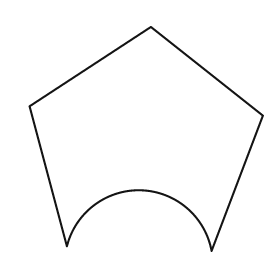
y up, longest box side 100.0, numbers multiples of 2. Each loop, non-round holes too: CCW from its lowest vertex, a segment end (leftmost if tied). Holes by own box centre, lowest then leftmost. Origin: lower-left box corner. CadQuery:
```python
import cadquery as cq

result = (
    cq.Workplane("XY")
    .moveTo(78.0, 0.0)
    .lineTo(100.0, 58.0)
    .lineTo(52.0, 96.0)
    .lineTo(0.0, 62.0)
    .lineTo(16.0, 2.0)
    .threePointArc((48.0, 26.0), (78.0, 0.0))
    .close()
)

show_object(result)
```